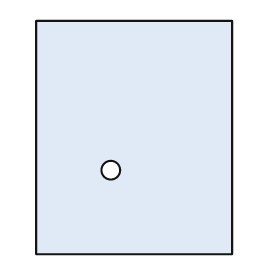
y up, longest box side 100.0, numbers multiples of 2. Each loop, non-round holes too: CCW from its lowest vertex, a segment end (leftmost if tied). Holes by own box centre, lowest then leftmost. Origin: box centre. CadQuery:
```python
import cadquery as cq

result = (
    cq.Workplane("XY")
    .moveTo(-42.0, -50.0)
    .lineTo(42.0, -50.0)
    .lineTo(42.0, 50.0)
    .lineTo(-42.0, 50.0)
    .close()
    .moveTo(-10.0, -14.0)
    .circle(4.0)
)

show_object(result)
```